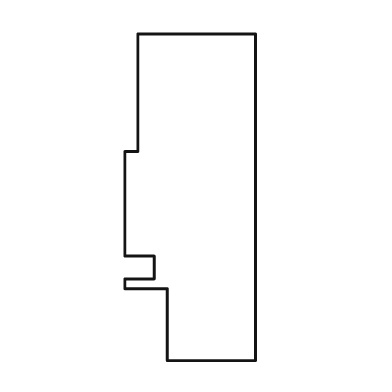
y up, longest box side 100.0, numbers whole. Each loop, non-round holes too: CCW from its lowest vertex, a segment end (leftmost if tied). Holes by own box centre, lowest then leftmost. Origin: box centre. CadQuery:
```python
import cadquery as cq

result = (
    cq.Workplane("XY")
    .moveTo(-7.0, -50.0)
    .lineTo(20.0, -50.0)
    .lineTo(20.0, 50.0)
    .lineTo(-16.0, 50.0)
    .lineTo(-16.0, 14.0)
    .lineTo(-20.0, 14.0)
    .lineTo(-20.0, -18.0)
    .lineTo(-11.0, -18.0)
    .lineTo(-11.0, -25.0)
    .lineTo(-20.0, -25.0)
    .lineTo(-20.0, -28.0)
    .lineTo(-7.0, -28.0)
    .close()
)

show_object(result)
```